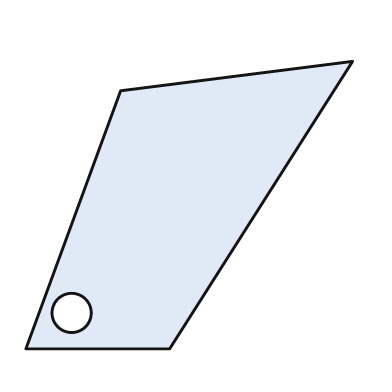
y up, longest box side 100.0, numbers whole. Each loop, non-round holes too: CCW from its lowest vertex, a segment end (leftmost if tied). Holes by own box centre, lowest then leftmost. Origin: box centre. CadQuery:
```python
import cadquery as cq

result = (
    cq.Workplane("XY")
    .moveTo(-50.0, -44.0)
    .lineTo(-6.0, -44.0)
    .lineTo(50.0, 44.0)
    .lineTo(-21.0, 35.0)
    .close()
    .moveTo(-36.0, -33.0)
    .circle(6.0)
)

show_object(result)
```